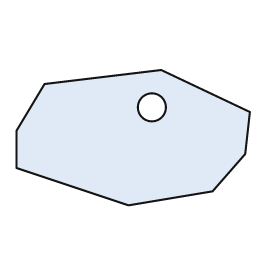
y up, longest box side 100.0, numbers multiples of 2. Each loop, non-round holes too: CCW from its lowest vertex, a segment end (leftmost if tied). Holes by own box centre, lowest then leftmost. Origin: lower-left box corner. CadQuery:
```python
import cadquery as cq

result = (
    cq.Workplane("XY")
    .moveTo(48.0, 0.0)
    .lineTo(84.0, 6.0)
    .lineTo(98.0, 22.0)
    .lineTo(100.0, 40.0)
    .lineTo(62.0, 58.0)
    .lineTo(12.0, 52.0)
    .lineTo(0.0, 32.0)
    .lineTo(0.0, 16.0)
    .close()
    .moveTo(58.0, 42.0)
    .circle(6.0)
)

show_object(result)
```